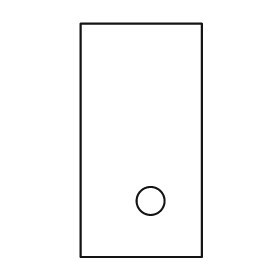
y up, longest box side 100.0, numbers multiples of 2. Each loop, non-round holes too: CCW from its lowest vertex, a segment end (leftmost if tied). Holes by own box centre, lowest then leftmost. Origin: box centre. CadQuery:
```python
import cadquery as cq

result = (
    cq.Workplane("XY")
    .moveTo(-26.0, -50.0)
    .lineTo(26.0, -50.0)
    .lineTo(26.0, 50.0)
    .lineTo(-26.0, 50.0)
    .close()
    .moveTo(4.0, -26.0)
    .circle(6.0)
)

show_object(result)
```